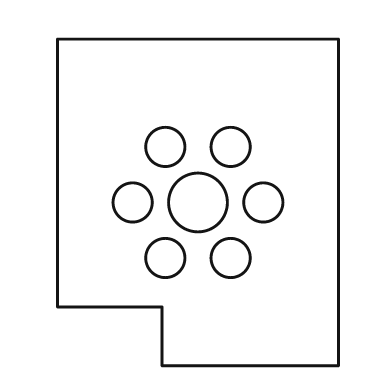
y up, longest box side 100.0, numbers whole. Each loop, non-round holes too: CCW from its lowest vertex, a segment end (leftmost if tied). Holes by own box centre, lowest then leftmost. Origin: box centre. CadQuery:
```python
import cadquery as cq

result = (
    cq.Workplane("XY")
    .moveTo(-11.0, -50.0)
    .lineTo(43.0, -50.0)
    .lineTo(43.0, 50.0)
    .lineTo(-43.0, 50.0)
    .lineTo(-43.0, -32.0)
    .lineTo(-11.0, -32.0)
    .close()
    .moveTo(-10.0, -17.0)
    .circle(6.0)
    .moveTo(10.0, -17.0)
    .circle(6.0)
    .moveTo(-20.0, 0.0)
    .circle(6.0)
    .moveTo(0.0, 0.0)
    .circle(9.0)
    .moveTo(20.0, 0.0)
    .circle(6.0)
    .moveTo(-10.0, 17.0)
    .circle(6.0)
    .moveTo(10.0, 17.0)
    .circle(6.0)
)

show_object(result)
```